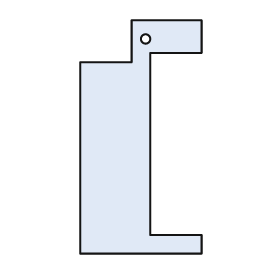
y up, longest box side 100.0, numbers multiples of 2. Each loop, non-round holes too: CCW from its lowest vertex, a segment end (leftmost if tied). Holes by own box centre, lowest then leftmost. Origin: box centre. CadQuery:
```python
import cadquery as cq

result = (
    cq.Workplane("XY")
    .moveTo(-26.0, -50.0)
    .lineTo(26.0, -50.0)
    .lineTo(26.0, -42.0)
    .lineTo(4.0, -42.0)
    .lineTo(4.0, 36.0)
    .lineTo(26.0, 36.0)
    .lineTo(26.0, 50.0)
    .lineTo(-4.0, 50.0)
    .lineTo(-4.0, 32.0)
    .lineTo(-26.0, 32.0)
    .close()
    .moveTo(2.0, 42.0)
    .circle(2.0)
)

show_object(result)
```